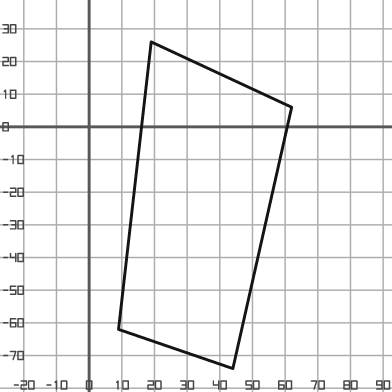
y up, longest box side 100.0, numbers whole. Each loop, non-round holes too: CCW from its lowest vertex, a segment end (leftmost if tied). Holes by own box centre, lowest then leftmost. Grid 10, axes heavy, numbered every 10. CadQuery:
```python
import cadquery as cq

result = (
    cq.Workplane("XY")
    .moveTo(44.0, -74.0)
    .lineTo(62.0, 6.0)
    .lineTo(19.0, 26.0)
    .lineTo(9.0, -62.0)
    .close()
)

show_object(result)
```